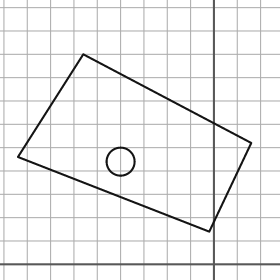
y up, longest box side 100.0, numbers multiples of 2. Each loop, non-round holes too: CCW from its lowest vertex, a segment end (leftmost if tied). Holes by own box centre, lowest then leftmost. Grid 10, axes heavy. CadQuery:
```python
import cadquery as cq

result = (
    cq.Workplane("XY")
    .moveTo(-2.0, 14.0)
    .lineTo(16.0, 52.0)
    .lineTo(-56.0, 90.0)
    .lineTo(-84.0, 46.0)
    .close()
    .moveTo(-40.0, 44.0)
    .circle(6.0)
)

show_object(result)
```